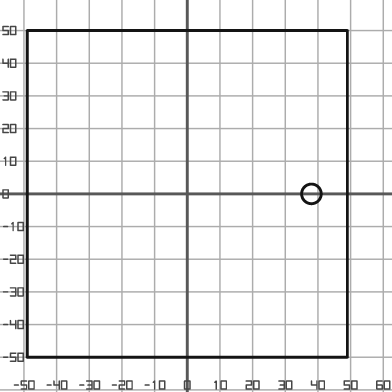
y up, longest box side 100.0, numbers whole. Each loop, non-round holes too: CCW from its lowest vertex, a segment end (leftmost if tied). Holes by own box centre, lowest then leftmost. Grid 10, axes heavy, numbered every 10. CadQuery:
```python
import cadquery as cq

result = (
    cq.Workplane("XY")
    .moveTo(-49.0, -50.0)
    .lineTo(49.0, -50.0)
    .lineTo(49.0, 50.0)
    .lineTo(-49.0, 50.0)
    .close()
    .moveTo(38.0, 0.0)
    .circle(3.0)
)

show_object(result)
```